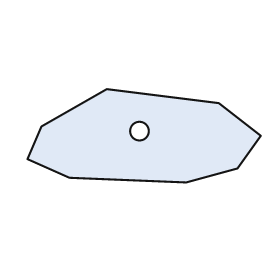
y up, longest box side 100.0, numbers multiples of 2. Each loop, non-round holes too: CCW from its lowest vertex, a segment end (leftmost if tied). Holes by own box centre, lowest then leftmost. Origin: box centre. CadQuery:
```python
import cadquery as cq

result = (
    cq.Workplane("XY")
    .moveTo(18.0, -20.0)
    .lineTo(40.0, -14.0)
    .lineTo(50.0, 0.0)
    .lineTo(32.0, 14.0)
    .lineTo(-16.0, 20.0)
    .lineTo(-44.0, 4.0)
    .lineTo(-50.0, -10.0)
    .lineTo(-32.0, -18.0)
    .close()
    .moveTo(-2.0, 2.0)
    .circle(4.0)
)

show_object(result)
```